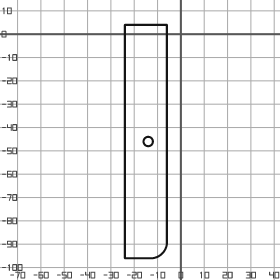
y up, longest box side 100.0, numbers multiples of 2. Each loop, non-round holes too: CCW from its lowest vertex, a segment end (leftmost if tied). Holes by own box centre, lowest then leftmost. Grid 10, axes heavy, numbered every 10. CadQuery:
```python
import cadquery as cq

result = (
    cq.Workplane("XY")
    .moveTo(-24.0, -96.0)
    .lineTo(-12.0, -96.0)
    .threePointArc((-8.0, -94.0), (-6.0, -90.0))
    .lineTo(-6.0, 4.0)
    .lineTo(-24.0, 4.0)
    .close()
    .moveTo(-14.0, -46.0)
    .circle(2.0)
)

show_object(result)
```